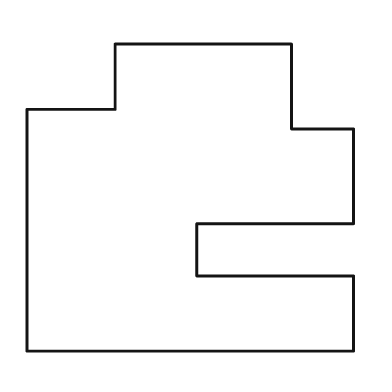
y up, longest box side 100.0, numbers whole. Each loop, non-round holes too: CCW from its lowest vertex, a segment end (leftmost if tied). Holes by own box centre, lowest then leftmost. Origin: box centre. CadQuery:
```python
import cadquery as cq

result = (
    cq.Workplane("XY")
    .moveTo(-50.0, -47.0)
    .lineTo(50.0, -47.0)
    .lineTo(50.0, -24.0)
    .lineTo(2.0, -24.0)
    .lineTo(2.0, -8.0)
    .lineTo(50.0, -8.0)
    .lineTo(50.0, 21.0)
    .lineTo(31.0, 21.0)
    .lineTo(31.0, 47.0)
    .lineTo(-23.0, 47.0)
    .lineTo(-23.0, 27.0)
    .lineTo(-50.0, 27.0)
    .close()
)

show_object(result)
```